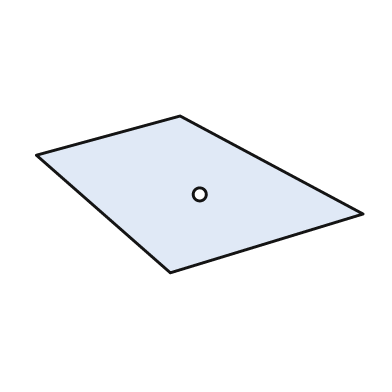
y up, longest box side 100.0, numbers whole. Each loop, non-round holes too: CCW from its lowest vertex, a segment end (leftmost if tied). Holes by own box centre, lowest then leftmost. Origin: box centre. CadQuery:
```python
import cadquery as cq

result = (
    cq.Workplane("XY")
    .moveTo(-9.0, -24.0)
    .lineTo(50.0, -6.0)
    .lineTo(-6.0, 24.0)
    .lineTo(-50.0, 12.0)
    .close()
    .moveTo(0.0, 0.0)
    .circle(2.0)
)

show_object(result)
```